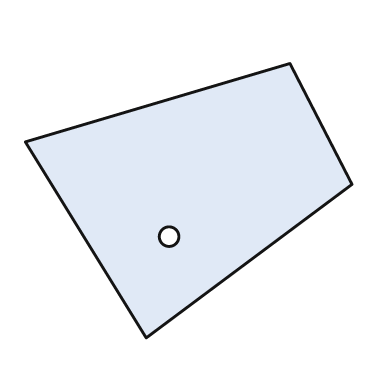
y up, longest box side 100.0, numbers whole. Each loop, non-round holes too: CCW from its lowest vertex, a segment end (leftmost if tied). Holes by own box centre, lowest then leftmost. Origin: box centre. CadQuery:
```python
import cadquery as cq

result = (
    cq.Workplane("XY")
    .moveTo(-13.0, -42.0)
    .lineTo(50.0, 5.0)
    .lineTo(31.0, 42.0)
    .lineTo(-50.0, 18.0)
    .close()
    .moveTo(-6.0, -11.0)
    .circle(3.0)
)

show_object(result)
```